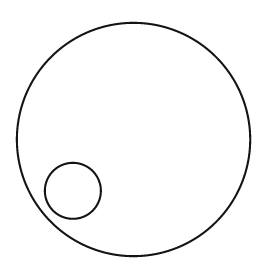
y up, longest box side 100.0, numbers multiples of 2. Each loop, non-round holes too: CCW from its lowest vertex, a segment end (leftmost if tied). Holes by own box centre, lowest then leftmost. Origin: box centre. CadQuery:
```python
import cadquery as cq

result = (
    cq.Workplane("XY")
    .moveTo(0.0, 0.0)
    .circle(50.0)
    .moveTo(-26.0, -22.0)
    .circle(12.0)
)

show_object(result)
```